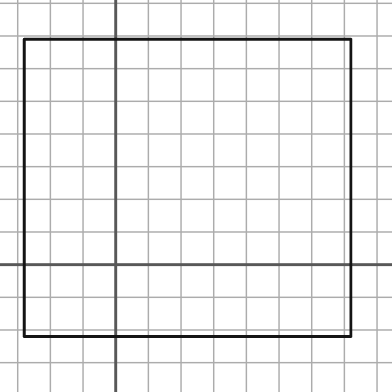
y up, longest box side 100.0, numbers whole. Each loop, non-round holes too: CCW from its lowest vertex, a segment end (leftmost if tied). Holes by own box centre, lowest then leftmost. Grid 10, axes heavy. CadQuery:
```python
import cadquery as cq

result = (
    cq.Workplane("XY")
    .moveTo(-28.0, -22.0)
    .lineTo(72.0, -22.0)
    .lineTo(72.0, 69.0)
    .lineTo(-28.0, 69.0)
    .close()
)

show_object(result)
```